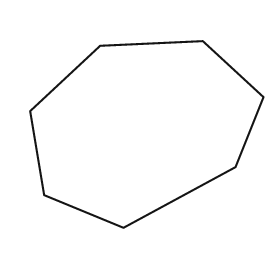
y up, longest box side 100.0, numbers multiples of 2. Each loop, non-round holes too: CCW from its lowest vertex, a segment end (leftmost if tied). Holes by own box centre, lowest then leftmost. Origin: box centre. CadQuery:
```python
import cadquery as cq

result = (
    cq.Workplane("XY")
    .moveTo(-10.0, -40.0)
    .lineTo(38.0, -14.0)
    .lineTo(50.0, 16.0)
    .lineTo(24.0, 40.0)
    .lineTo(-20.0, 38.0)
    .lineTo(-50.0, 10.0)
    .lineTo(-44.0, -26.0)
    .close()
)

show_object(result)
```